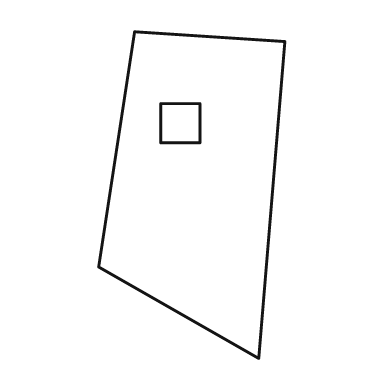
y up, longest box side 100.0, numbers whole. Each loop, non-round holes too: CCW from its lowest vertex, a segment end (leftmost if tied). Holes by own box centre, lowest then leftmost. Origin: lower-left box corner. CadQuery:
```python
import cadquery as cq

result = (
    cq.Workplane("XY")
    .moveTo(49.0, 0.0)
    .lineTo(57.0, 97.0)
    .lineTo(11.0, 100.0)
    .lineTo(0.0, 28.0)
    .close()
    .moveTo(19.0, 66.0)
    .lineTo(31.0, 66.0)
    .lineTo(31.0, 78.0)
    .lineTo(19.0, 78.0)
    .close()
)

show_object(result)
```